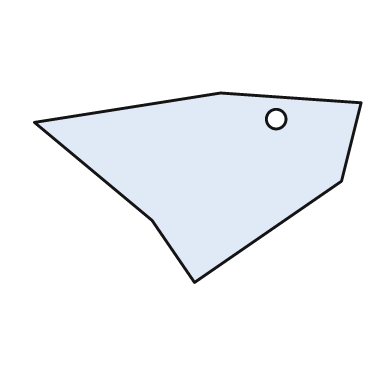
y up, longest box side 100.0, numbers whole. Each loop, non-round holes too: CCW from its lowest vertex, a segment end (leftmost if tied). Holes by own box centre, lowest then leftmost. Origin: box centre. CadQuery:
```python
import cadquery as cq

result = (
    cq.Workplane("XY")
    .moveTo(-1.0, -29.0)
    .lineTo(44.0, 2.0)
    .lineTo(50.0, 26.0)
    .lineTo(7.0, 29.0)
    .lineTo(-50.0, 20.0)
    .lineTo(-14.0, -10.0)
    .close()
    .moveTo(24.0, 21.0)
    .circle(3.0)
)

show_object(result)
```